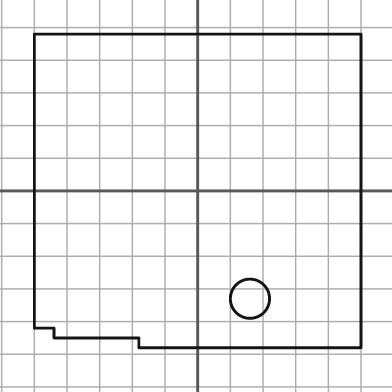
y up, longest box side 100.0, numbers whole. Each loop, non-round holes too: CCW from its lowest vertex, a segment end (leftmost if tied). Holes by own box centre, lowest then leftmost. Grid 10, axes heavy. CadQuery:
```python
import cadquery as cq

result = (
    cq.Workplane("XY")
    .moveTo(-18.0, -48.0)
    .lineTo(50.0, -48.0)
    .lineTo(50.0, 48.0)
    .lineTo(-50.0, 48.0)
    .lineTo(-50.0, -42.0)
    .lineTo(-44.0, -42.0)
    .lineTo(-44.0, -45.0)
    .lineTo(-18.0, -45.0)
    .close()
    .moveTo(16.0, -33.0)
    .circle(6.0)
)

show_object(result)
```